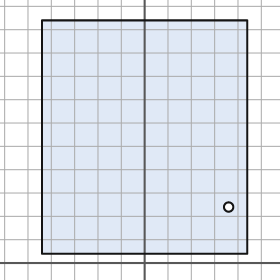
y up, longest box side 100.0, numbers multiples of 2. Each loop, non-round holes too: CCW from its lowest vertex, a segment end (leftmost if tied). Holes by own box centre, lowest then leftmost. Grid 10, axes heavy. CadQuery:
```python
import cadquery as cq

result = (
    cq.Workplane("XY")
    .moveTo(-44.0, 4.0)
    .lineTo(44.0, 4.0)
    .lineTo(44.0, 104.0)
    .lineTo(-44.0, 104.0)
    .close()
    .moveTo(36.0, 24.0)
    .circle(2.0)
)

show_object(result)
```